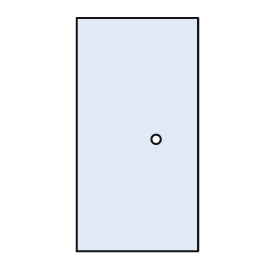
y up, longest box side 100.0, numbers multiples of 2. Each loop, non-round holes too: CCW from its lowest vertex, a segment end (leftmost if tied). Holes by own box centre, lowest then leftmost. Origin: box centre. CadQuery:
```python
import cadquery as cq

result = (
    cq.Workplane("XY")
    .moveTo(-26.0, -50.0)
    .lineTo(26.0, -50.0)
    .lineTo(26.0, 50.0)
    .lineTo(-26.0, 50.0)
    .close()
    .moveTo(8.0, -2.0)
    .circle(2.0)
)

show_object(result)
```